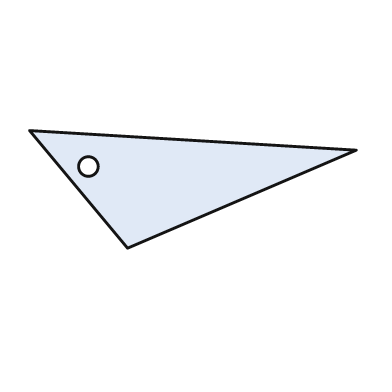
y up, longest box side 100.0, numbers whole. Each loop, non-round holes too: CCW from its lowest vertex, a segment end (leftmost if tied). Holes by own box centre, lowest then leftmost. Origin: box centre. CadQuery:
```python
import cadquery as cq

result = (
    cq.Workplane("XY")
    .moveTo(-20.0, -18.0)
    .lineTo(50.0, 12.0)
    .lineTo(-50.0, 18.0)
    .close()
    .moveTo(-32.0, 7.0)
    .circle(3.0)
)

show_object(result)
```